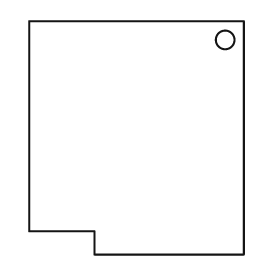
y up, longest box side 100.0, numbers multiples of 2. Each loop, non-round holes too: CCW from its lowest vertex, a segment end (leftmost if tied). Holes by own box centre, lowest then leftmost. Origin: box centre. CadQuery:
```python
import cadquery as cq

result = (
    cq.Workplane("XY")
    .moveTo(-18.0, -50.0)
    .lineTo(46.0, -50.0)
    .lineTo(46.0, 50.0)
    .lineTo(-46.0, 50.0)
    .lineTo(-46.0, -40.0)
    .lineTo(-18.0, -40.0)
    .close()
    .moveTo(38.0, 42.0)
    .circle(4.0)
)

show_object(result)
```